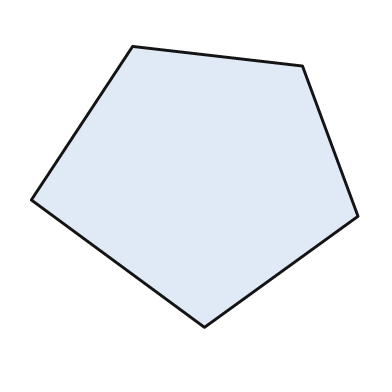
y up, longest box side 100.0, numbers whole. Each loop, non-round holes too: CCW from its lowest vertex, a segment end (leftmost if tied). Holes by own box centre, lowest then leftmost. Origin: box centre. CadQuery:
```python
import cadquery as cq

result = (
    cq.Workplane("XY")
    .moveTo(3.0, -43.0)
    .lineTo(50.0, -9.0)
    .lineTo(33.0, 37.0)
    .lineTo(-19.0, 43.0)
    .lineTo(-50.0, -4.0)
    .close()
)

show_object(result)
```